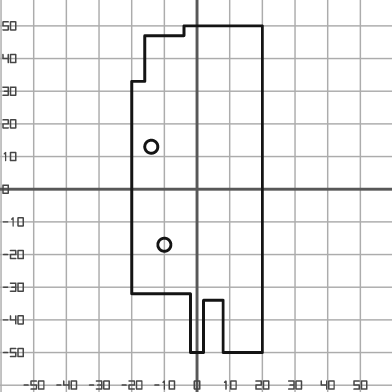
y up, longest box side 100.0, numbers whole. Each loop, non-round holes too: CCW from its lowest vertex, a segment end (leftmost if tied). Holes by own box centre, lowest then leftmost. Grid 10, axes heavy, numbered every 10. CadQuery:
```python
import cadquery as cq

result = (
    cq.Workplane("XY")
    .moveTo(-2.0, -50.0)
    .lineTo(2.0, -50.0)
    .lineTo(2.0, -34.0)
    .lineTo(8.0, -34.0)
    .lineTo(8.0, -50.0)
    .lineTo(20.0, -50.0)
    .lineTo(20.0, 50.0)
    .lineTo(-4.0, 50.0)
    .lineTo(-4.0, 47.0)
    .lineTo(-16.0, 47.0)
    .lineTo(-16.0, 33.0)
    .lineTo(-20.0, 33.0)
    .lineTo(-20.0, -32.0)
    .lineTo(-2.0, -32.0)
    .close()
    .moveTo(-10.0, -17.0)
    .circle(2.0)
    .moveTo(-14.0, 13.0)
    .circle(2.0)
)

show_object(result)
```